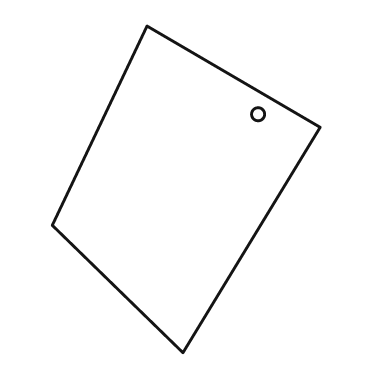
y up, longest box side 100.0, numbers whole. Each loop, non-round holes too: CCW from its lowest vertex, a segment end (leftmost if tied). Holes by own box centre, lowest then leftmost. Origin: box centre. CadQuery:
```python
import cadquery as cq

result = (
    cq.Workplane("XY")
    .moveTo(-1.0, -50.0)
    .lineTo(41.0, 19.0)
    .lineTo(-12.0, 50.0)
    .lineTo(-41.0, -11.0)
    .close()
    .moveTo(22.0, 23.0)
    .circle(2.0)
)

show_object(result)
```